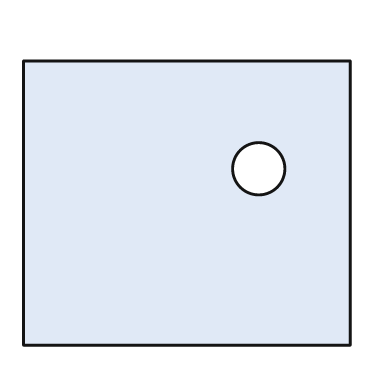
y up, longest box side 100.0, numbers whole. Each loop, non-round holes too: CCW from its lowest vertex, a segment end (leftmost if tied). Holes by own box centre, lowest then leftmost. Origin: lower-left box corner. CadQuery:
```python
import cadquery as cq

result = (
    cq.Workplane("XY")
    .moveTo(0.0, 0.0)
    .lineTo(100.0, 0.0)
    .lineTo(100.0, 87.0)
    .lineTo(0.0, 87.0)
    .close()
    .moveTo(72.0, 54.0)
    .circle(8.0)
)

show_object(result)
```